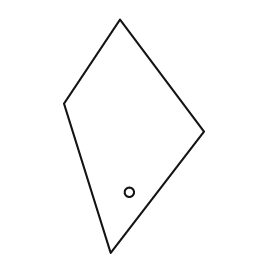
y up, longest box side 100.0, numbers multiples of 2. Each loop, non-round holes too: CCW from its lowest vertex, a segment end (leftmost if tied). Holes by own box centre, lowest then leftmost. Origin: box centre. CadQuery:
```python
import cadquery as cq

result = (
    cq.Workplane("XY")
    .moveTo(-10.0, -50.0)
    .lineTo(30.0, 2.0)
    .lineTo(-6.0, 50.0)
    .lineTo(-30.0, 14.0)
    .close()
    .moveTo(-2.0, -24.0)
    .circle(2.0)
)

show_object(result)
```